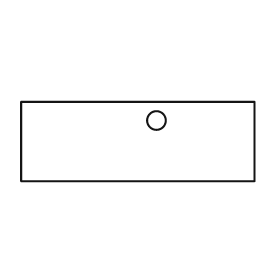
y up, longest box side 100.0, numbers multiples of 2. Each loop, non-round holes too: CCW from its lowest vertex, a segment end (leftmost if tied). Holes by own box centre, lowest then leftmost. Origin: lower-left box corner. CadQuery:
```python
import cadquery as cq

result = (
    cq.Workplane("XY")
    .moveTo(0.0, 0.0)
    .lineTo(100.0, 0.0)
    .lineTo(100.0, 34.0)
    .lineTo(0.0, 34.0)
    .close()
    .moveTo(58.0, 26.0)
    .circle(4.0)
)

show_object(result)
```